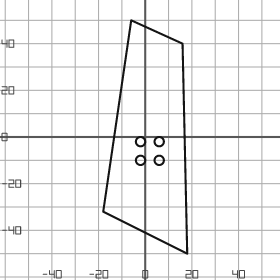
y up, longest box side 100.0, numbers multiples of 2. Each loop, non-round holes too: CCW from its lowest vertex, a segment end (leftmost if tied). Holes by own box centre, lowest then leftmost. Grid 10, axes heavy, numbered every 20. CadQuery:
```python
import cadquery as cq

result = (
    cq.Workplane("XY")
    .moveTo(18.0, -50.0)
    .lineTo(16.0, 40.0)
    .lineTo(-6.0, 50.0)
    .lineTo(-18.0, -32.0)
    .close()
    .moveTo(-2.0, -10.0)
    .circle(2.0)
    .moveTo(6.0, -10.0)
    .circle(2.0)
    .moveTo(-2.0, -2.0)
    .circle(2.0)
    .moveTo(6.0, -2.0)
    .circle(2.0)
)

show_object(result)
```